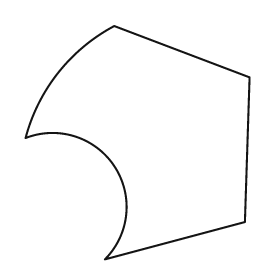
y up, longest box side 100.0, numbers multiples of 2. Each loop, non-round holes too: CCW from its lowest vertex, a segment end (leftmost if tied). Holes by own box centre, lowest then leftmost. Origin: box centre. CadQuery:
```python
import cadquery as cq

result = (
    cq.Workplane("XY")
    .moveTo(-14.0, -50.0)
    .lineTo(46.0, -34.0)
    .lineTo(48.0, 28.0)
    .lineTo(-10.0, 50.0)
    .threePointArc((-34.0, 30.0), (-48.0, 2.0))
    .threePointArc((-10.0, -10.0), (-14.0, -50.0))
    .close()
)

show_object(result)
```